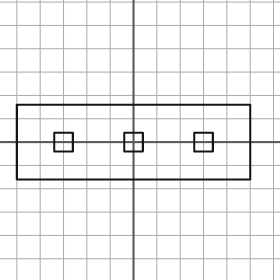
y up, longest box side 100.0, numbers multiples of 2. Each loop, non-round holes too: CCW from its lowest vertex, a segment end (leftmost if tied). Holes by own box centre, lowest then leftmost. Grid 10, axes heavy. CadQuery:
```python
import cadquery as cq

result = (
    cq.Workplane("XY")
    .moveTo(-50.0, -16.0)
    .lineTo(50.0, -16.0)
    .lineTo(50.0, 16.0)
    .lineTo(-50.0, 16.0)
    .close()
    .moveTo(-34.0, -4.0)
    .lineTo(-26.0, -4.0)
    .lineTo(-26.0, 4.0)
    .lineTo(-34.0, 4.0)
    .close()
    .moveTo(-4.0, -4.0)
    .lineTo(4.0, -4.0)
    .lineTo(4.0, 4.0)
    .lineTo(-4.0, 4.0)
    .close()
    .moveTo(26.0, -4.0)
    .lineTo(34.0, -4.0)
    .lineTo(34.0, 4.0)
    .lineTo(26.0, 4.0)
    .close()
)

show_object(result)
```